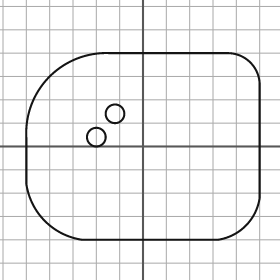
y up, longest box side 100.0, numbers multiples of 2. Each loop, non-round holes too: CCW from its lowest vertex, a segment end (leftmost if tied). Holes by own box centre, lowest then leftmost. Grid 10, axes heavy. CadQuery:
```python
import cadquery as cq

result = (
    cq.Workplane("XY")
    .moveTo(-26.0, -40.0)
    .lineTo(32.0, -40.0)
    .threePointArc((44.0, -34.0), (50.0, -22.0))
    .lineTo(50.0, 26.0)
    .threePointArc((46.0, 36.0), (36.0, 40.0))
    .lineTo(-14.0, 40.0)
    .threePointArc((-40.0, 30.0), (-50.0, 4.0))
    .lineTo(-50.0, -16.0)
    .threePointArc((-42.0, -32.0), (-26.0, -40.0))
    .close()
    .moveTo(-20.0, 4.0)
    .circle(4.0)
    .moveTo(-12.0, 14.0)
    .circle(4.0)
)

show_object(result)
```